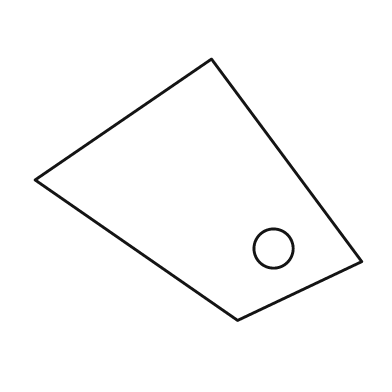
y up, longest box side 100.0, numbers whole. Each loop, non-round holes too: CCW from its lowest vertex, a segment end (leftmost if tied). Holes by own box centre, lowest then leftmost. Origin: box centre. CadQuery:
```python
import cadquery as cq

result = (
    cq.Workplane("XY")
    .moveTo(12.0, -40.0)
    .lineTo(50.0, -22.0)
    .lineTo(4.0, 40.0)
    .lineTo(-50.0, 3.0)
    .close()
    .moveTo(23.0, -18.0)
    .circle(6.0)
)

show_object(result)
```